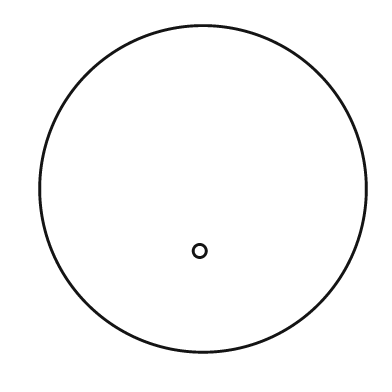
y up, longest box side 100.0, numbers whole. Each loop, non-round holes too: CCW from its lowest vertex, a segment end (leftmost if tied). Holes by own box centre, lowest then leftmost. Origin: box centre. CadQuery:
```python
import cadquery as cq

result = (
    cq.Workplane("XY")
    .moveTo(0.0, 0.0)
    .circle(50.0)
    .moveTo(-1.0, -19.0)
    .circle(2.0)
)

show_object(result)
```